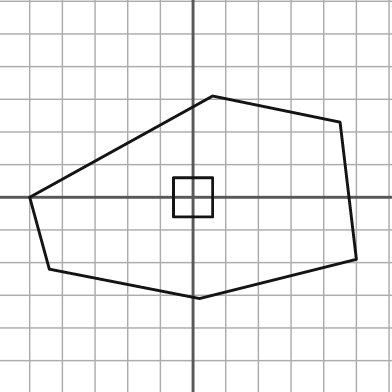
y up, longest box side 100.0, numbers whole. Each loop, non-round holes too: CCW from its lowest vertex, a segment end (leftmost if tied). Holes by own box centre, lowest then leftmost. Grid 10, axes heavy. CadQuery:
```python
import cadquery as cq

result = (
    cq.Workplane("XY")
    .moveTo(2.0, -31.0)
    .lineTo(50.0, -19.0)
    .lineTo(45.0, 23.0)
    .lineTo(6.0, 31.0)
    .lineTo(-50.0, 0.0)
    .lineTo(-44.0, -22.0)
    .close()
    .moveTo(-6.0, -6.0)
    .lineTo(6.0, -6.0)
    .lineTo(6.0, 6.0)
    .lineTo(-6.0, 6.0)
    .close()
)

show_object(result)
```